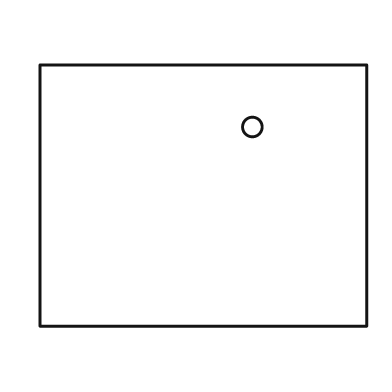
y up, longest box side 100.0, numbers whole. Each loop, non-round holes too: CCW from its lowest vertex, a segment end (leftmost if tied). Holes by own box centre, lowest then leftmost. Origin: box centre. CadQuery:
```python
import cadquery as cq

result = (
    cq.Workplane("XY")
    .moveTo(-50.0, -40.0)
    .lineTo(50.0, -40.0)
    .lineTo(50.0, 40.0)
    .lineTo(-50.0, 40.0)
    .close()
    .moveTo(15.0, 21.0)
    .circle(3.0)
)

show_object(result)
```